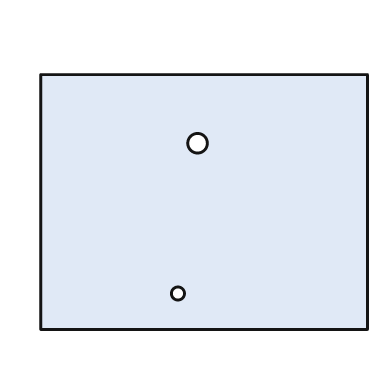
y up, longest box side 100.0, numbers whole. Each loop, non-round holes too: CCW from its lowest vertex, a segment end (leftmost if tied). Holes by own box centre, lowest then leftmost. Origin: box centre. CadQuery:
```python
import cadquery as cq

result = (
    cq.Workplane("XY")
    .moveTo(-50.0, -39.0)
    .lineTo(50.0, -39.0)
    .lineTo(50.0, 39.0)
    .lineTo(-50.0, 39.0)
    .close()
    .moveTo(-8.0, -28.0)
    .circle(2.0)
    .moveTo(-2.0, 18.0)
    .circle(3.0)
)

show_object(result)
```